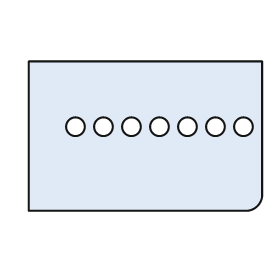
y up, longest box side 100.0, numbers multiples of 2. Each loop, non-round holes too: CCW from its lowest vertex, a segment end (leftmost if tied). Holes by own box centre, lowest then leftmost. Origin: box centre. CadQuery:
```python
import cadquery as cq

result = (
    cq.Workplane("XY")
    .moveTo(-50.0, -32.0)
    .lineTo(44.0, -32.0)
    .threePointArc((48.0, -30.0), (50.0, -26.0))
    .lineTo(50.0, 32.0)
    .lineTo(-50.0, 32.0)
    .close()
    .moveTo(-30.0, 4.0)
    .circle(4.0)
    .moveTo(-18.0, 4.0)
    .circle(4.0)
    .moveTo(-6.0, 4.0)
    .circle(4.0)
    .moveTo(6.0, 4.0)
    .circle(4.0)
    .moveTo(18.0, 4.0)
    .circle(4.0)
    .moveTo(30.0, 4.0)
    .circle(4.0)
    .moveTo(42.0, 4.0)
    .circle(4.0)
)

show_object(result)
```